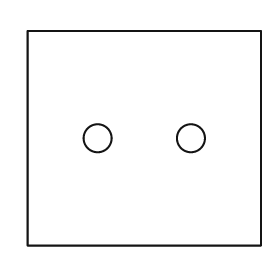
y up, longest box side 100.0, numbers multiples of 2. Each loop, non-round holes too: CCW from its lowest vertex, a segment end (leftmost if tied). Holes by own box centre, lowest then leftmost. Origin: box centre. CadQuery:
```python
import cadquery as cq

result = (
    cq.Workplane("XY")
    .moveTo(-50.0, -46.0)
    .lineTo(50.0, -46.0)
    .lineTo(50.0, 46.0)
    .lineTo(-50.0, 46.0)
    .close()
    .moveTo(-20.0, 0.0)
    .circle(6.0)
    .moveTo(20.0, 0.0)
    .circle(6.0)
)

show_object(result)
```